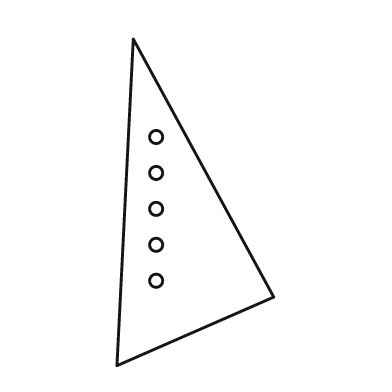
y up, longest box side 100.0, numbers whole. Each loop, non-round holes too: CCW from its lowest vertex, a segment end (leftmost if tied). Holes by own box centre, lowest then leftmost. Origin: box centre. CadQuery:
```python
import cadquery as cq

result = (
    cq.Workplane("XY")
    .moveTo(-24.0, -50.0)
    .lineTo(24.0, -29.0)
    .lineTo(-19.0, 50.0)
    .close()
    .moveTo(-12.0, -24.0)
    .circle(2.0)
    .moveTo(-12.0, -13.0)
    .circle(2.0)
    .moveTo(-12.0, -2.0)
    .circle(2.0)
    .moveTo(-12.0, 9.0)
    .circle(2.0)
    .moveTo(-12.0, 20.0)
    .circle(2.0)
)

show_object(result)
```